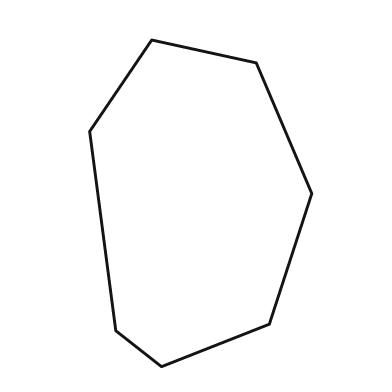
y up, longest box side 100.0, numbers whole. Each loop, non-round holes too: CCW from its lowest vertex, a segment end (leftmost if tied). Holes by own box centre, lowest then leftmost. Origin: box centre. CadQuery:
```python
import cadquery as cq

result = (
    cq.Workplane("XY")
    .moveTo(-12.0, -50.0)
    .lineTo(21.0, -37.0)
    .lineTo(34.0, 3.0)
    .lineTo(17.0, 43.0)
    .lineTo(-15.0, 50.0)
    .lineTo(-34.0, 22.0)
    .lineTo(-26.0, -39.0)
    .close()
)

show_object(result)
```